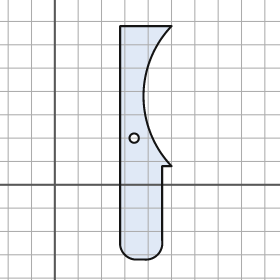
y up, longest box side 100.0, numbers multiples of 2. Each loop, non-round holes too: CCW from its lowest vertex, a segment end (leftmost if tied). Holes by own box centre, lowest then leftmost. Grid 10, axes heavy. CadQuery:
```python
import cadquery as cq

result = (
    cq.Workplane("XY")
    .moveTo(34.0, -32.0)
    .lineTo(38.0, -32.0)
    .threePointArc((44.0, -30.0), (46.0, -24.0))
    .lineTo(46.0, 8.0)
    .lineTo(50.0, 8.0)
    .threePointArc((38.0, 38.0), (50.0, 68.0))
    .lineTo(28.0, 68.0)
    .lineTo(28.0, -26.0)
    .threePointArc((30.0, -30.0), (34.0, -32.0))
    .close()
    .moveTo(34.0, 20.0)
    .circle(2.0)
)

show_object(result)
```